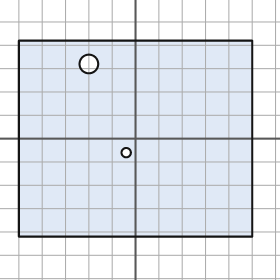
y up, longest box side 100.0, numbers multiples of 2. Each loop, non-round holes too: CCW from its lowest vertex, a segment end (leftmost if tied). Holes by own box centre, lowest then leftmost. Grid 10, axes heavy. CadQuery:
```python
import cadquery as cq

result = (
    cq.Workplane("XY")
    .moveTo(-50.0, -42.0)
    .lineTo(50.0, -42.0)
    .lineTo(50.0, 42.0)
    .lineTo(-50.0, 42.0)
    .close()
    .moveTo(-4.0, -6.0)
    .circle(2.0)
    .moveTo(-20.0, 32.0)
    .circle(4.0)
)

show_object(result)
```